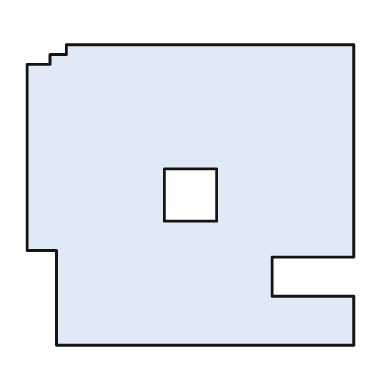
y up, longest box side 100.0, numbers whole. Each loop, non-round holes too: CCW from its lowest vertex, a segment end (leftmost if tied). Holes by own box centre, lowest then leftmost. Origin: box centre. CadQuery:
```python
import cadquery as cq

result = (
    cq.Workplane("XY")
    .moveTo(-41.0, -46.0)
    .lineTo(50.0, -46.0)
    .lineTo(50.0, -31.0)
    .lineTo(25.0, -31.0)
    .lineTo(25.0, -19.0)
    .lineTo(50.0, -19.0)
    .lineTo(50.0, 46.0)
    .lineTo(-38.0, 46.0)
    .lineTo(-38.0, 43.0)
    .lineTo(-43.0, 43.0)
    .lineTo(-43.0, 40.0)
    .lineTo(-50.0, 40.0)
    .lineTo(-50.0, -17.0)
    .lineTo(-41.0, -17.0)
    .close()
    .moveTo(-8.0, -8.0)
    .lineTo(8.0, -8.0)
    .lineTo(8.0, 8.0)
    .lineTo(-8.0, 8.0)
    .close()
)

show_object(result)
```